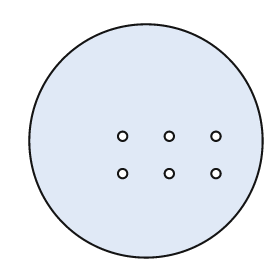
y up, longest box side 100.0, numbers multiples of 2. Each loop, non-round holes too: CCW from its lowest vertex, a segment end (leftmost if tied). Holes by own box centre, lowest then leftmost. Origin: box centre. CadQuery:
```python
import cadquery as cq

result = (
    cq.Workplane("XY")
    .moveTo(0.0, 0.0)
    .circle(50.0)
    .moveTo(-10.0, -14.0)
    .circle(2.0)
    .moveTo(10.0, -14.0)
    .circle(2.0)
    .moveTo(30.0, -14.0)
    .circle(2.0)
    .moveTo(-10.0, 2.0)
    .circle(2.0)
    .moveTo(10.0, 2.0)
    .circle(2.0)
    .moveTo(30.0, 2.0)
    .circle(2.0)
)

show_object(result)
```